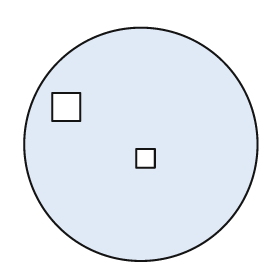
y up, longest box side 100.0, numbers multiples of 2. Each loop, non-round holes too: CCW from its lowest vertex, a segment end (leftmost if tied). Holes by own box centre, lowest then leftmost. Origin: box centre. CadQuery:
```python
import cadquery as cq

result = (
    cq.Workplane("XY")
    .moveTo(0.0, 0.0)
    .circle(50.0)
    .moveTo(-2.0, -10.0)
    .lineTo(6.0, -10.0)
    .lineTo(6.0, -2.0)
    .lineTo(-2.0, -2.0)
    .close()
    .moveTo(-38.0, 10.0)
    .lineTo(-26.0, 10.0)
    .lineTo(-26.0, 22.0)
    .lineTo(-38.0, 22.0)
    .close()
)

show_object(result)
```